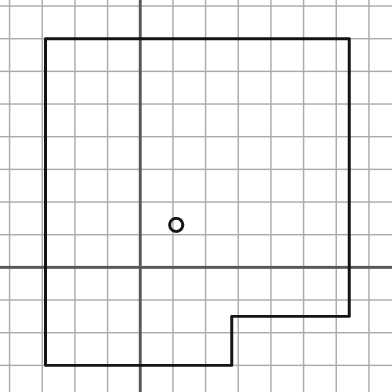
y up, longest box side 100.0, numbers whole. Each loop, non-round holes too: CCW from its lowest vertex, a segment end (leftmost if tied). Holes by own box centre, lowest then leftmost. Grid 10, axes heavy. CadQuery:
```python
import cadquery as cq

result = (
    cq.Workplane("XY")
    .moveTo(-29.0, -30.0)
    .lineTo(28.0, -30.0)
    .lineTo(28.0, -15.0)
    .lineTo(64.0, -15.0)
    .lineTo(64.0, 70.0)
    .lineTo(-29.0, 70.0)
    .close()
    .moveTo(11.0, 13.0)
    .circle(2.0)
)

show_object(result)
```